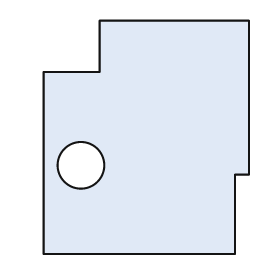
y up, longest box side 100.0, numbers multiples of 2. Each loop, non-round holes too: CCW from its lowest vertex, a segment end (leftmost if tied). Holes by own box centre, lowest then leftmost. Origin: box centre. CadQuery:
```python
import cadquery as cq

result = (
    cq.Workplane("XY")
    .moveTo(-44.0, -50.0)
    .lineTo(38.0, -50.0)
    .lineTo(38.0, -16.0)
    .lineTo(44.0, -16.0)
    .lineTo(44.0, 50.0)
    .lineTo(-20.0, 50.0)
    .lineTo(-20.0, 28.0)
    .lineTo(-44.0, 28.0)
    .close()
    .moveTo(-28.0, -12.0)
    .circle(10.0)
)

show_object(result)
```